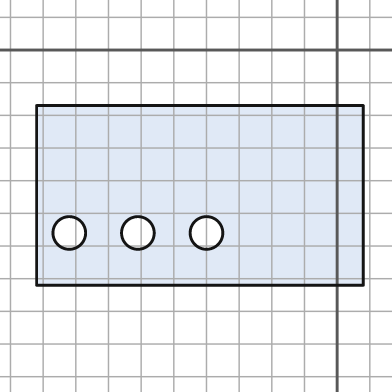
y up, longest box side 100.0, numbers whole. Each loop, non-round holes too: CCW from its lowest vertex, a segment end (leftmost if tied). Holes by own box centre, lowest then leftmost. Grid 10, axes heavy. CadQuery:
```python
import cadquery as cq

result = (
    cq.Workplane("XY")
    .moveTo(-92.0, -72.0)
    .lineTo(8.0, -72.0)
    .lineTo(8.0, -17.0)
    .lineTo(-92.0, -17.0)
    .close()
    .moveTo(-82.0, -56.0)
    .circle(5.0)
    .moveTo(-61.0, -56.0)
    .circle(5.0)
    .moveTo(-40.0, -56.0)
    .circle(5.0)
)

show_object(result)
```